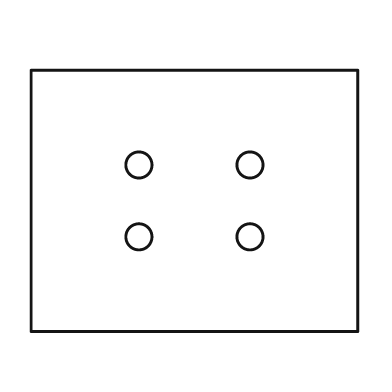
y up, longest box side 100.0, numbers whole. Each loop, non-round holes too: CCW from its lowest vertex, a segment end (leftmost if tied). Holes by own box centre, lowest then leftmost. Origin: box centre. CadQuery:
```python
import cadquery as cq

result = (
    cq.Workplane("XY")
    .moveTo(-50.0, -40.0)
    .lineTo(50.0, -40.0)
    .lineTo(50.0, 40.0)
    .lineTo(-50.0, 40.0)
    .close()
    .moveTo(-17.0, -11.0)
    .circle(4.0)
    .moveTo(17.0, -11.0)
    .circle(4.0)
    .moveTo(-17.0, 11.0)
    .circle(4.0)
    .moveTo(17.0, 11.0)
    .circle(4.0)
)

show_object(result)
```